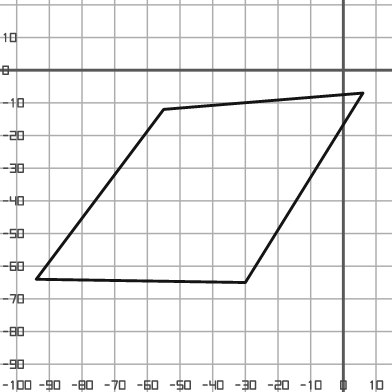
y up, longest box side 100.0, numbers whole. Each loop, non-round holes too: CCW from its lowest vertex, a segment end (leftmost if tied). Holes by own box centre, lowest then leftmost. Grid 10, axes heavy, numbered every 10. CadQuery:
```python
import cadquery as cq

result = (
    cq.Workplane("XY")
    .moveTo(-30.0, -65.0)
    .lineTo(6.0, -7.0)
    .lineTo(-55.0, -12.0)
    .lineTo(-94.0, -64.0)
    .close()
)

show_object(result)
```